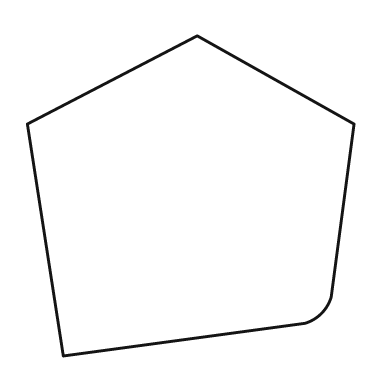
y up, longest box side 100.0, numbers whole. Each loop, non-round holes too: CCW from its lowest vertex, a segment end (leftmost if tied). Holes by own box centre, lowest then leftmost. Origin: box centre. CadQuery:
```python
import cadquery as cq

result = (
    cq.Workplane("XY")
    .moveTo(-39.0, -49.0)
    .lineTo(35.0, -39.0)
    .threePointArc((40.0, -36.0), (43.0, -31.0))
    .lineTo(50.0, 22.0)
    .lineTo(2.0, 49.0)
    .lineTo(-50.0, 22.0)
    .close()
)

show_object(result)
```